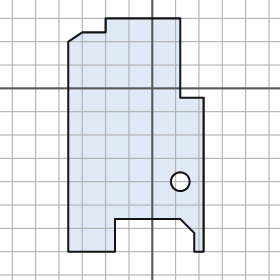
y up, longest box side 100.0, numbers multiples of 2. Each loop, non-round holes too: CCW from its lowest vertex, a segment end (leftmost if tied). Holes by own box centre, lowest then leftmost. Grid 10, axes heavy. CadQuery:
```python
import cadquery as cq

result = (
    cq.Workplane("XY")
    .moveTo(-36.0, -70.0)
    .lineTo(-16.0, -70.0)
    .lineTo(-16.0, -56.0)
    .lineTo(12.0, -56.0)
    .lineTo(18.0, -62.0)
    .lineTo(18.0, -70.0)
    .lineTo(22.0, -70.0)
    .lineTo(22.0, -4.0)
    .lineTo(12.0, -4.0)
    .lineTo(12.0, 30.0)
    .lineTo(-20.0, 30.0)
    .lineTo(-20.0, 24.0)
    .lineTo(-30.0, 24.0)
    .lineTo(-36.0, 20.0)
    .close()
    .moveTo(12.0, -40.0)
    .circle(4.0)
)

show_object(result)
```